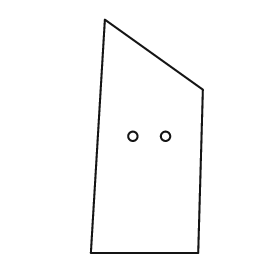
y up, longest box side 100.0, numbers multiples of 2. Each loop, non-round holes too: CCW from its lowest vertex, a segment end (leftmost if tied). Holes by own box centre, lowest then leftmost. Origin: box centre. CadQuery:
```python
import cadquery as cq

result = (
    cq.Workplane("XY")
    .moveTo(-24.0, -50.0)
    .lineTo(22.0, -50.0)
    .lineTo(24.0, 20.0)
    .lineTo(-18.0, 50.0)
    .close()
    .moveTo(-6.0, 0.0)
    .circle(2.0)
    .moveTo(8.0, 0.0)
    .circle(2.0)
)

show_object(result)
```